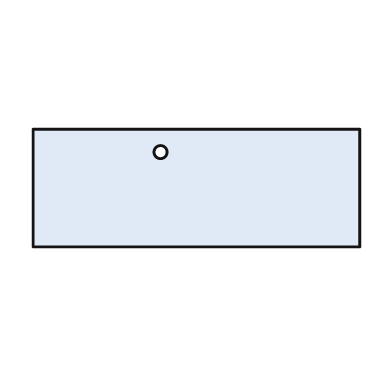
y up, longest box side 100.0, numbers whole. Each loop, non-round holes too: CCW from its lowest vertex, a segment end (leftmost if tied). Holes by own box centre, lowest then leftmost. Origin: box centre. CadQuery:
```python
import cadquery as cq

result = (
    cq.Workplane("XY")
    .moveTo(-50.0, -18.0)
    .lineTo(50.0, -18.0)
    .lineTo(50.0, 18.0)
    .lineTo(-50.0, 18.0)
    .close()
    .moveTo(-11.0, 11.0)
    .circle(2.0)
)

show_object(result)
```